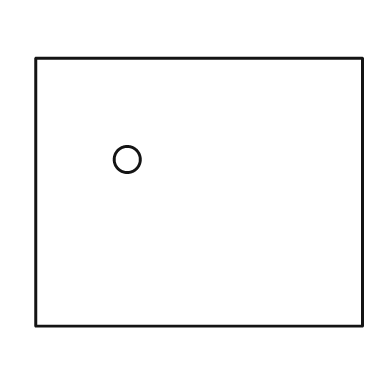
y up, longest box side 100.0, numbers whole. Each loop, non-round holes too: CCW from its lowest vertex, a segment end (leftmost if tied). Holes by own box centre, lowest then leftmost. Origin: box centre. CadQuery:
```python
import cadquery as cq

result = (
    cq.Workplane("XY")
    .moveTo(-50.0, -41.0)
    .lineTo(50.0, -41.0)
    .lineTo(50.0, 41.0)
    .lineTo(-50.0, 41.0)
    .close()
    .moveTo(-22.0, 10.0)
    .circle(4.0)
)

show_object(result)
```